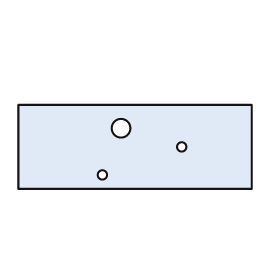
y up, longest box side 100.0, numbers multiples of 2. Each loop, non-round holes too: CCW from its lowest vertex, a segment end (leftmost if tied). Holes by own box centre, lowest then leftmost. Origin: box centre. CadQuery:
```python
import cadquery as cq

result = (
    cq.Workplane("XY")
    .moveTo(-50.0, -18.0)
    .lineTo(50.0, -18.0)
    .lineTo(50.0, 18.0)
    .lineTo(-50.0, 18.0)
    .close()
    .moveTo(-14.0, -12.0)
    .circle(2.0)
    .moveTo(20.0, 0.0)
    .circle(2.0)
    .moveTo(-6.0, 8.0)
    .circle(4.0)
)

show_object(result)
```